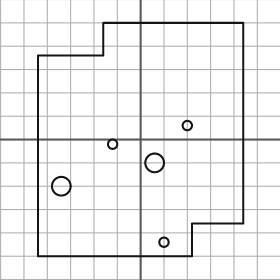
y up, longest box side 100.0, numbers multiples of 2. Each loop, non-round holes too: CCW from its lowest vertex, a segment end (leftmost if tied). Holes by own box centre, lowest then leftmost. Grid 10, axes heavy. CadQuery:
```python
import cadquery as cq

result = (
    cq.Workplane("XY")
    .moveTo(-44.0, -50.0)
    .lineTo(22.0, -50.0)
    .lineTo(22.0, -36.0)
    .lineTo(44.0, -36.0)
    .lineTo(44.0, 50.0)
    .lineTo(-16.0, 50.0)
    .lineTo(-16.0, 36.0)
    .lineTo(-44.0, 36.0)
    .close()
    .moveTo(10.0, -44.0)
    .circle(2.0)
    .moveTo(-34.0, -20.0)
    .circle(4.0)
    .moveTo(6.0, -10.0)
    .circle(4.0)
    .moveTo(-12.0, -2.0)
    .circle(2.0)
    .moveTo(20.0, 6.0)
    .circle(2.0)
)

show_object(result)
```